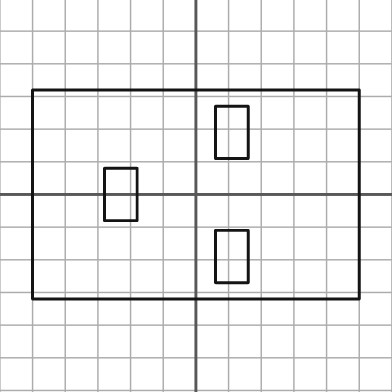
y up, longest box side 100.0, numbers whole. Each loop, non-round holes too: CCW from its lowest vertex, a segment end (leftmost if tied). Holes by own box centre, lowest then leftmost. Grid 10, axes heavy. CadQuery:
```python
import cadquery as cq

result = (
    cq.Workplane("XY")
    .moveTo(-50.0, -32.0)
    .lineTo(50.0, -32.0)
    .lineTo(50.0, 32.0)
    .lineTo(-50.0, 32.0)
    .close()
    .moveTo(6.0, -27.0)
    .lineTo(16.0, -27.0)
    .lineTo(16.0, -11.0)
    .lineTo(6.0, -11.0)
    .close()
    .moveTo(-28.0, -8.0)
    .lineTo(-18.0, -8.0)
    .lineTo(-18.0, 8.0)
    .lineTo(-28.0, 8.0)
    .close()
    .moveTo(6.0, 11.0)
    .lineTo(16.0, 11.0)
    .lineTo(16.0, 27.0)
    .lineTo(6.0, 27.0)
    .close()
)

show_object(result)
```